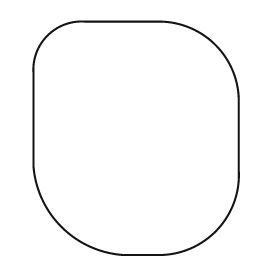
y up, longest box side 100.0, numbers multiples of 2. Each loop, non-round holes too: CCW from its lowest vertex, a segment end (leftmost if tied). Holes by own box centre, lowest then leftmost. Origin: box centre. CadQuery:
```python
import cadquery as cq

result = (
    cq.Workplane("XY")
    .moveTo(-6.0, -50.0)
    .lineTo(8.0, -50.0)
    .threePointArc((34.0, -40.0), (44.0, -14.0))
    .lineTo(44.0, 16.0)
    .threePointArc((34.0, 40.0), (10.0, 50.0))
    .lineTo(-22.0, 50.0)
    .threePointArc((-38.0, 44.0), (-44.0, 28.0))
    .lineTo(-44.0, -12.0)
    .threePointArc((-32.0, -38.0), (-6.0, -50.0))
    .close()
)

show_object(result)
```